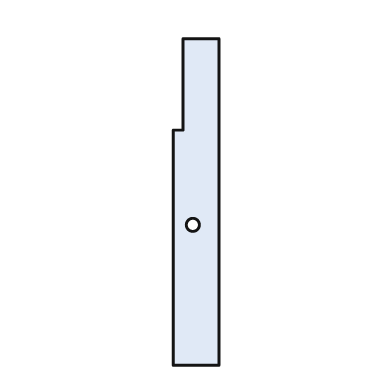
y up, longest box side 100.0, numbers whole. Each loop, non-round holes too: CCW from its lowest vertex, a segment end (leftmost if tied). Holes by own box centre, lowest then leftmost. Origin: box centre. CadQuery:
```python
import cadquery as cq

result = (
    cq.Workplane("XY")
    .moveTo(-7.0, -50.0)
    .lineTo(7.0, -50.0)
    .lineTo(7.0, 50.0)
    .lineTo(-4.0, 50.0)
    .lineTo(-4.0, 22.0)
    .lineTo(-7.0, 22.0)
    .close()
    .moveTo(-1.0, -7.0)
    .circle(2.0)
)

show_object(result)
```